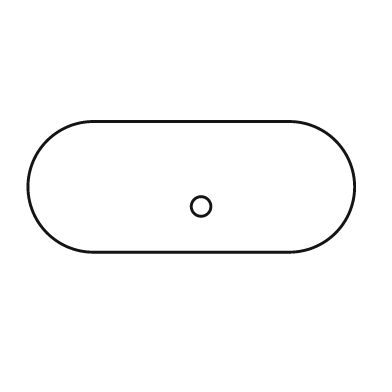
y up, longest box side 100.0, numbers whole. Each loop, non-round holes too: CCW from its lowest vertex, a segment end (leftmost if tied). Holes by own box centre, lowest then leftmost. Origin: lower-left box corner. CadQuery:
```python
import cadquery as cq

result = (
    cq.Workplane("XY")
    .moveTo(20.0, 0.0)
    .lineTo(80.0, 0.0)
    .threePointArc((100.0, 20.0), (80.0, 40.0))
    .lineTo(20.0, 40.0)
    .threePointArc((0.0, 20.0), (20.0, 0.0))
    .close()
    .moveTo(53.0, 14.0)
    .circle(3.0)
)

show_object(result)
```